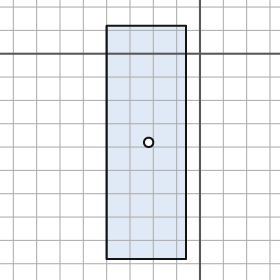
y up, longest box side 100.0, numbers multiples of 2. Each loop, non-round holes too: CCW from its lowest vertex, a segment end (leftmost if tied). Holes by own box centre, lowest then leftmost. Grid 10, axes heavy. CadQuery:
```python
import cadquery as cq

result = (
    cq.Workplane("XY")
    .moveTo(-40.0, -88.0)
    .lineTo(-6.0, -88.0)
    .lineTo(-6.0, 12.0)
    .lineTo(-40.0, 12.0)
    .close()
    .moveTo(-22.0, -38.0)
    .circle(2.0)
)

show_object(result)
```